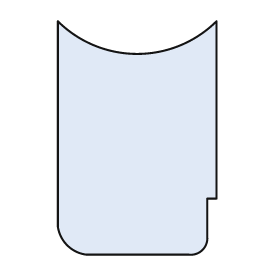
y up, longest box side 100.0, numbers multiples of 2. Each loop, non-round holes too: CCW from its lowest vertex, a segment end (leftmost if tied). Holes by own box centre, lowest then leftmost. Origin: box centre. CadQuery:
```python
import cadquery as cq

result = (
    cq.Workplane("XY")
    .moveTo(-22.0, -50.0)
    .lineTo(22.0, -50.0)
    .threePointArc((28.0, -48.0), (30.0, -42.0))
    .lineTo(30.0, -26.0)
    .lineTo(34.0, -26.0)
    .lineTo(34.0, 50.0)
    .threePointArc((0.0, 36.0), (-34.0, 50.0))
    .lineTo(-34.0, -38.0)
    .threePointArc((-30.0, -46.0), (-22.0, -50.0))
    .close()
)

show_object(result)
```